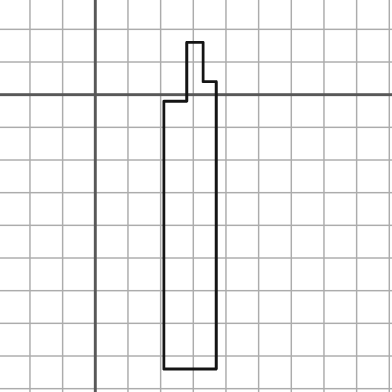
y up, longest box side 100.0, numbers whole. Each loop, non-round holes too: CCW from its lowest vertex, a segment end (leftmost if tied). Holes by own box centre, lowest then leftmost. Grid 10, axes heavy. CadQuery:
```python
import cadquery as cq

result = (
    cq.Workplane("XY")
    .moveTo(21.0, -84.0)
    .lineTo(37.0, -84.0)
    .lineTo(37.0, 4.0)
    .lineTo(33.0, 4.0)
    .lineTo(33.0, 16.0)
    .lineTo(28.0, 16.0)
    .lineTo(28.0, -2.0)
    .lineTo(21.0, -2.0)
    .close()
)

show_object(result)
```